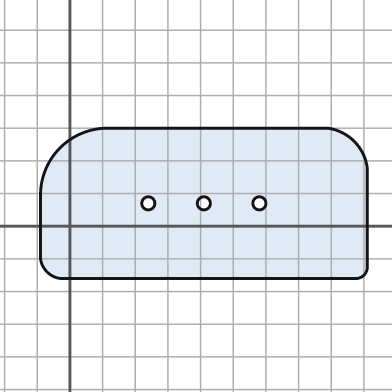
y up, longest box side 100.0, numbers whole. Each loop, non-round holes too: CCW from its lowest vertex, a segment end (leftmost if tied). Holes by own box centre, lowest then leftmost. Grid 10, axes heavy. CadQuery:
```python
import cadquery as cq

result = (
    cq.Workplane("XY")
    .moveTo(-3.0, -16.0)
    .lineTo(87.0, -16.0)
    .threePointArc((90.0, -15.0), (91.0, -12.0))
    .lineTo(91.0, 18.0)
    .threePointArc((87.0, 26.0), (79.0, 30.0))
    .lineTo(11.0, 30.0)
    .threePointArc((-3.0, 24.0), (-9.0, 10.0))
    .lineTo(-9.0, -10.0)
    .threePointArc((-7.0, -14.0), (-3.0, -16.0))
    .close()
    .moveTo(24.0, 7.0)
    .circle(2.0)
    .moveTo(41.0, 7.0)
    .circle(2.0)
    .moveTo(58.0, 7.0)
    .circle(2.0)
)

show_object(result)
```